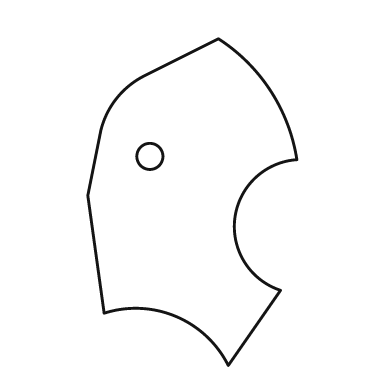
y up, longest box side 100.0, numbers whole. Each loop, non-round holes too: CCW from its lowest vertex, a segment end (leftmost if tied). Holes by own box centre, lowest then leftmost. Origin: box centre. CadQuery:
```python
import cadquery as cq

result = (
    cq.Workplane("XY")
    .moveTo(11.0, -50.0)
    .lineTo(27.0, -27.0)
    .threePointArc((13.0, -5.0), (32.0, 13.0))
    .threePointArc((24.0, 34.0), (8.0, 50.0))
    .lineTo(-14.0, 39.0)
    .threePointArc((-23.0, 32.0), (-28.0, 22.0))
    .lineTo(-32.0, 2.0)
    .lineTo(-27.0, -34.0)
    .threePointArc((-5.0, -35.0), (11.0, -50.0))
    .close()
    .moveTo(-13.0, 14.0)
    .circle(4.0)
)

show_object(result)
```